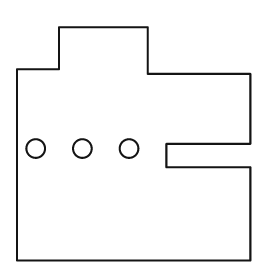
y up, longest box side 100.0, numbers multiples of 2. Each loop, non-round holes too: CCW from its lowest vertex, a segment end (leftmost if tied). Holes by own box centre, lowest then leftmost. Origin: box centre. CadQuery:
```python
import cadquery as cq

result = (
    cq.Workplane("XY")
    .moveTo(-50.0, -50.0)
    .lineTo(50.0, -50.0)
    .lineTo(50.0, -10.0)
    .lineTo(14.0, -10.0)
    .lineTo(14.0, 0.0)
    .lineTo(50.0, 0.0)
    .lineTo(50.0, 30.0)
    .lineTo(6.0, 30.0)
    .lineTo(6.0, 50.0)
    .lineTo(-32.0, 50.0)
    .lineTo(-32.0, 32.0)
    .lineTo(-50.0, 32.0)
    .close()
    .moveTo(-42.0, -2.0)
    .circle(4.0)
    .moveTo(-22.0, -2.0)
    .circle(4.0)
    .moveTo(-2.0, -2.0)
    .circle(4.0)
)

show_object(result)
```